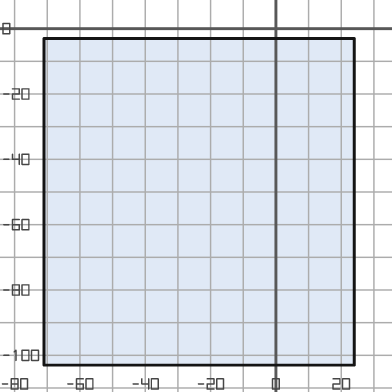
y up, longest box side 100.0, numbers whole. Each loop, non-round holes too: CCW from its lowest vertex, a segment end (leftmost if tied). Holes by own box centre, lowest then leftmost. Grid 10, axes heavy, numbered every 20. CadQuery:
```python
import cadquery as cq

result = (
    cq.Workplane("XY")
    .moveTo(-71.0, -103.0)
    .lineTo(24.0, -103.0)
    .lineTo(24.0, -3.0)
    .lineTo(-71.0, -3.0)
    .close()
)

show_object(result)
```